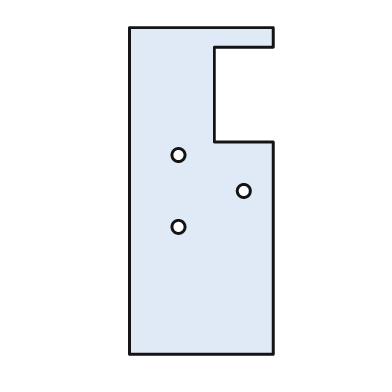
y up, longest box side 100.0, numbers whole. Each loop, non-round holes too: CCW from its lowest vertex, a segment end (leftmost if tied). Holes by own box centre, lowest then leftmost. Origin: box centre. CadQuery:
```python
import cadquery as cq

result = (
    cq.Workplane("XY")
    .moveTo(-22.0, -50.0)
    .lineTo(22.0, -50.0)
    .lineTo(22.0, 15.0)
    .lineTo(4.0, 15.0)
    .lineTo(4.0, 44.0)
    .lineTo(22.0, 44.0)
    .lineTo(22.0, 50.0)
    .lineTo(-22.0, 50.0)
    .close()
    .moveTo(-7.0, -11.0)
    .circle(2.0)
    .moveTo(13.0, 0.0)
    .circle(2.0)
    .moveTo(-7.0, 11.0)
    .circle(2.0)
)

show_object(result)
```